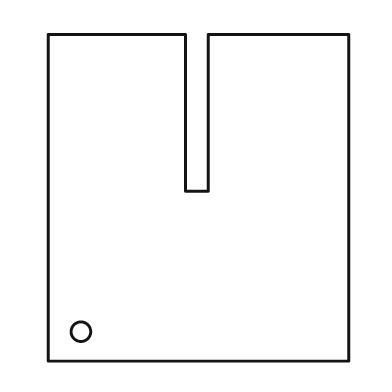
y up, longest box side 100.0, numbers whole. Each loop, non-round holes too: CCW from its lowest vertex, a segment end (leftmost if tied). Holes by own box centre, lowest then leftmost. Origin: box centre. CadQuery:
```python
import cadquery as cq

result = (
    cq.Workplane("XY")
    .moveTo(-46.0, -50.0)
    .lineTo(46.0, -50.0)
    .lineTo(46.0, 50.0)
    .lineTo(3.0, 50.0)
    .lineTo(3.0, 2.0)
    .lineTo(-4.0, 2.0)
    .lineTo(-4.0, 50.0)
    .lineTo(-46.0, 50.0)
    .close()
    .moveTo(-36.0, -41.0)
    .circle(3.0)
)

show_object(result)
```